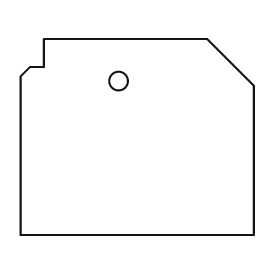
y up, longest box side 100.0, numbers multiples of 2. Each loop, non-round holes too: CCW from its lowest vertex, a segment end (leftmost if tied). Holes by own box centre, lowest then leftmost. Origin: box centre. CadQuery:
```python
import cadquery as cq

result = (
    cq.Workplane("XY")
    .moveTo(-50.0, -42.0)
    .lineTo(50.0, -42.0)
    .lineTo(50.0, 22.0)
    .lineTo(30.0, 42.0)
    .lineTo(-40.0, 42.0)
    .lineTo(-40.0, 30.0)
    .lineTo(-46.0, 30.0)
    .lineTo(-50.0, 26.0)
    .close()
    .moveTo(-8.0, 24.0)
    .circle(4.0)
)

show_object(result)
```